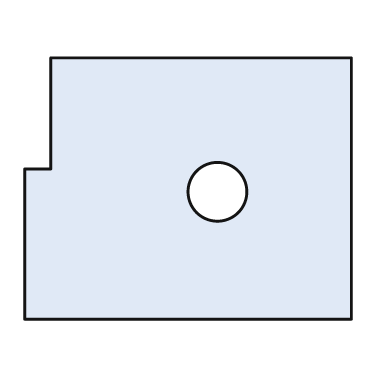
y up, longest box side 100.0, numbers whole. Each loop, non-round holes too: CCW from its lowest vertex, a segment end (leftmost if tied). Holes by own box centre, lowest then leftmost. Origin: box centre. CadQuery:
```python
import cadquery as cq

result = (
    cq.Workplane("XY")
    .moveTo(-50.0, -40.0)
    .lineTo(50.0, -40.0)
    .lineTo(50.0, 40.0)
    .lineTo(-42.0, 40.0)
    .lineTo(-42.0, 6.0)
    .lineTo(-50.0, 6.0)
    .close()
    .moveTo(9.0, -1.0)
    .circle(9.0)
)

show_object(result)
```